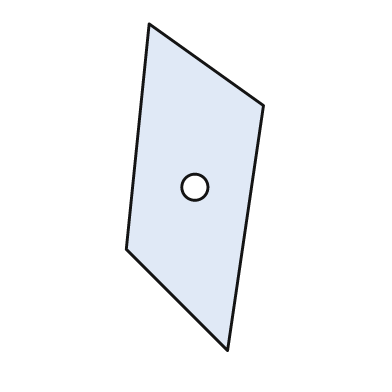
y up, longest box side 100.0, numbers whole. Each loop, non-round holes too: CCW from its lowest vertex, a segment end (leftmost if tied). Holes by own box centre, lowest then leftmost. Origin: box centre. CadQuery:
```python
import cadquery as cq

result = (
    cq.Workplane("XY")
    .moveTo(10.0, -50.0)
    .lineTo(21.0, 25.0)
    .lineTo(-14.0, 50.0)
    .lineTo(-21.0, -19.0)
    .close()
    .moveTo(0.0, 0.0)
    .circle(4.0)
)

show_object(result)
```